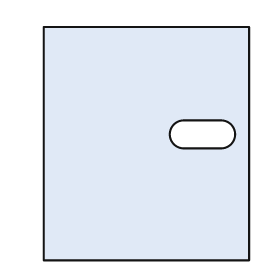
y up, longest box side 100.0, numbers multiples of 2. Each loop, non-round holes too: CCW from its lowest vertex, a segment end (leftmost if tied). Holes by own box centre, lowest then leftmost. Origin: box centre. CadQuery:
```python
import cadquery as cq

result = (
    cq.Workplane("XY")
    .moveTo(-44.0, -50.0)
    .lineTo(44.0, -50.0)
    .lineTo(44.0, 50.0)
    .lineTo(-44.0, 50.0)
    .close()
    .moveTo(16.0, -2.0)
    .lineTo(32.0, -2.0)
    .threePointArc((38.0, 4.0), (32.0, 10.0))
    .lineTo(16.0, 10.0)
    .threePointArc((10.0, 4.0), (16.0, -2.0))
    .close()
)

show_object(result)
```